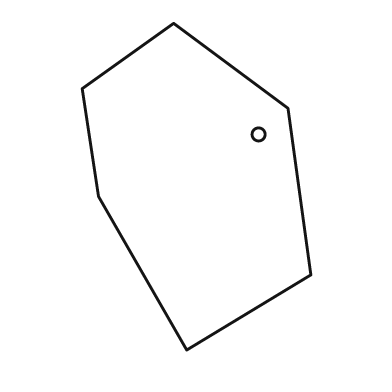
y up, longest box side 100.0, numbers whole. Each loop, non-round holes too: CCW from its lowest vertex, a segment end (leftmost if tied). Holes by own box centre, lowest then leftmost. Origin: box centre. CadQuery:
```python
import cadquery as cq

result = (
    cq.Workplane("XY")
    .moveTo(-3.0, -50.0)
    .lineTo(35.0, -27.0)
    .lineTo(28.0, 24.0)
    .lineTo(-7.0, 50.0)
    .lineTo(-35.0, 30.0)
    .lineTo(-30.0, -3.0)
    .close()
    .moveTo(19.0, 16.0)
    .circle(2.0)
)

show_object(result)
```